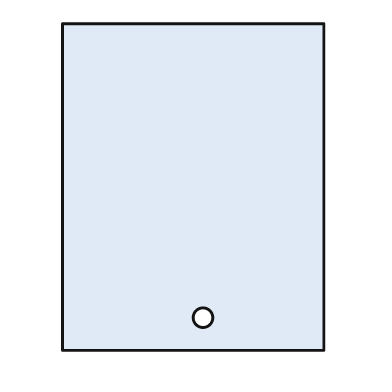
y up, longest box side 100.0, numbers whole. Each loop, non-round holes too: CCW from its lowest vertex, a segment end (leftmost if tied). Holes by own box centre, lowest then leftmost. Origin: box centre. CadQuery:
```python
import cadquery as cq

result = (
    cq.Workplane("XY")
    .moveTo(-40.0, -50.0)
    .lineTo(40.0, -50.0)
    .lineTo(40.0, 50.0)
    .lineTo(-40.0, 50.0)
    .close()
    .moveTo(3.0, -40.0)
    .circle(3.0)
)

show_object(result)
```